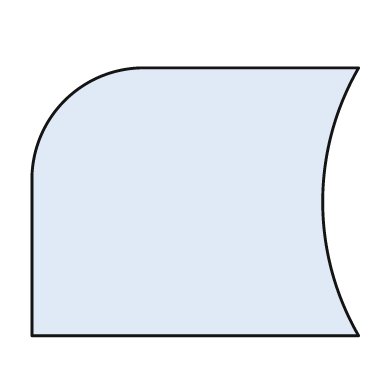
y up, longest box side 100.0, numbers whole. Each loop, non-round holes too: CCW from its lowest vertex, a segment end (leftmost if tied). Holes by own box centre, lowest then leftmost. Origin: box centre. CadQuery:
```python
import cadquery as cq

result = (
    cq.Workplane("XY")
    .moveTo(-50.0, -41.0)
    .lineTo(50.0, -41.0)
    .threePointArc((39.0, 0.0), (50.0, 41.0))
    .lineTo(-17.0, 41.0)
    .threePointArc((-40.0, 31.0), (-50.0, 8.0))
    .close()
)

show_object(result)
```